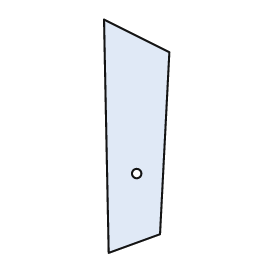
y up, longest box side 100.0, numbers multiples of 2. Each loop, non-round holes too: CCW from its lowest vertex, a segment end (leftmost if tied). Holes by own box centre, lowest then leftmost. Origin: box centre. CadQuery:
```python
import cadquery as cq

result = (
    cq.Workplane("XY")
    .moveTo(-12.0, -50.0)
    .lineTo(10.0, -42.0)
    .lineTo(14.0, 36.0)
    .lineTo(-14.0, 50.0)
    .close()
    .moveTo(0.0, -16.0)
    .circle(2.0)
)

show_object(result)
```